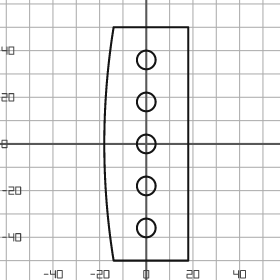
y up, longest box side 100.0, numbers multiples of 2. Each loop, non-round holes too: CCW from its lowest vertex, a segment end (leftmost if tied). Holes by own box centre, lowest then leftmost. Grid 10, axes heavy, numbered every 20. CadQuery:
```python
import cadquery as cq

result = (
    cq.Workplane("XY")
    .moveTo(-14.0, -50.0)
    .lineTo(18.0, -50.0)
    .lineTo(18.0, 50.0)
    .lineTo(-14.0, 50.0)
    .threePointArc((-18.0, 0.0), (-14.0, -50.0))
    .close()
    .moveTo(0.0, -36.0)
    .circle(4.0)
    .moveTo(0.0, -18.0)
    .circle(4.0)
    .moveTo(0.0, 0.0)
    .circle(4.0)
    .moveTo(0.0, 18.0)
    .circle(4.0)
    .moveTo(0.0, 36.0)
    .circle(4.0)
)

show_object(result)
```